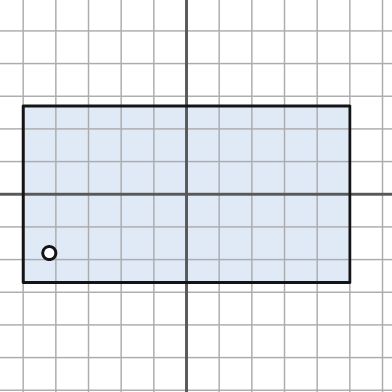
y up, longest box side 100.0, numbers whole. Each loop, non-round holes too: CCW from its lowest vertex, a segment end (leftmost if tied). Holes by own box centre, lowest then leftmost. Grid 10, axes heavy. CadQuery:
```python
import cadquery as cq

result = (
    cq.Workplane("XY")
    .moveTo(-50.0, -27.0)
    .lineTo(50.0, -27.0)
    .lineTo(50.0, 27.0)
    .lineTo(-50.0, 27.0)
    .close()
    .moveTo(-42.0, -18.0)
    .circle(2.0)
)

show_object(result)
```